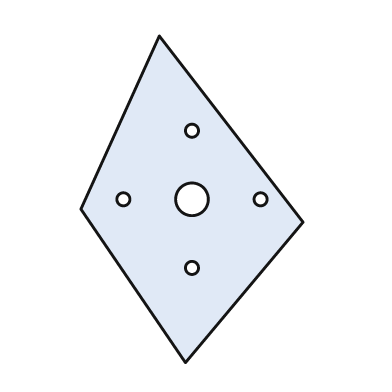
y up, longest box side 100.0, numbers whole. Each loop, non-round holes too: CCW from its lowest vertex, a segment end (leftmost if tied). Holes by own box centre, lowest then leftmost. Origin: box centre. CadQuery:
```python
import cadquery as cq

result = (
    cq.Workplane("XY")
    .moveTo(-2.0, -50.0)
    .lineTo(34.0, -7.0)
    .lineTo(-10.0, 50.0)
    .lineTo(-34.0, -3.0)
    .close()
    .moveTo(0.0, -21.0)
    .circle(2.0)
    .moveTo(-21.0, 0.0)
    .circle(2.0)
    .moveTo(0.0, 0.0)
    .circle(5.0)
    .moveTo(21.0, 0.0)
    .circle(2.0)
    .moveTo(0.0, 21.0)
    .circle(2.0)
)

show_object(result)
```